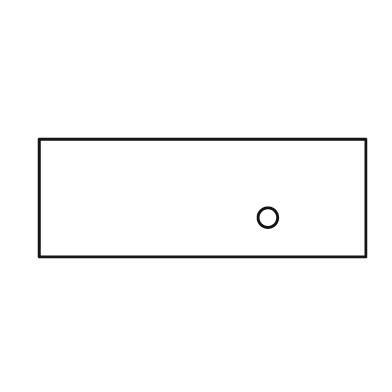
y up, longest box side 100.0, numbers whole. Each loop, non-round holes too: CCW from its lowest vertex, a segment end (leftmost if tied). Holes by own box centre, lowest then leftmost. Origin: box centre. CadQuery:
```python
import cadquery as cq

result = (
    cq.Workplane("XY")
    .moveTo(-50.0, -18.0)
    .lineTo(50.0, -18.0)
    .lineTo(50.0, 18.0)
    .lineTo(-50.0, 18.0)
    .close()
    .moveTo(20.0, -6.0)
    .circle(3.0)
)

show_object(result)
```